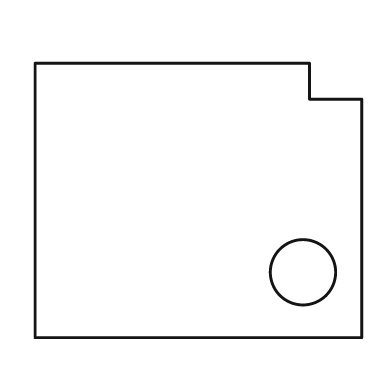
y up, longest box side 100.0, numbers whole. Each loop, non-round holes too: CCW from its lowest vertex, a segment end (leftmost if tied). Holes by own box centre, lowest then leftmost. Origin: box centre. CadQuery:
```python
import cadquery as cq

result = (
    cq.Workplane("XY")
    .moveTo(-50.0, -42.0)
    .lineTo(50.0, -42.0)
    .lineTo(50.0, 31.0)
    .lineTo(34.0, 31.0)
    .lineTo(34.0, 42.0)
    .lineTo(-50.0, 42.0)
    .close()
    .moveTo(32.0, -22.0)
    .circle(10.0)
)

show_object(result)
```